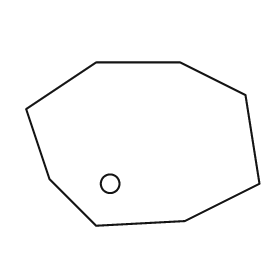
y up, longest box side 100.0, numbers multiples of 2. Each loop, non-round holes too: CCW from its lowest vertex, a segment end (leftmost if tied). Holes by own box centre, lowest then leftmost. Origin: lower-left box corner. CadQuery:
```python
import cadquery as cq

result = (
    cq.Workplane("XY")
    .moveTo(30.0, 0.0)
    .lineTo(68.0, 2.0)
    .lineTo(100.0, 18.0)
    .lineTo(94.0, 56.0)
    .lineTo(66.0, 70.0)
    .lineTo(30.0, 70.0)
    .lineTo(0.0, 50.0)
    .lineTo(10.0, 20.0)
    .close()
    .moveTo(36.0, 18.0)
    .circle(4.0)
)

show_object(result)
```